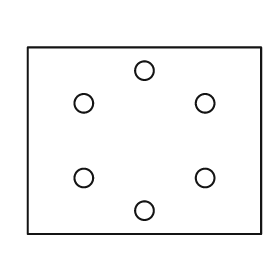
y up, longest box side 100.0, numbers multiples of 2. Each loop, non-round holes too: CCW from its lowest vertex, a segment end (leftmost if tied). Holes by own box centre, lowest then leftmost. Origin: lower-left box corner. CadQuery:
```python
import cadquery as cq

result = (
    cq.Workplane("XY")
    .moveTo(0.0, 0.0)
    .lineTo(100.0, 0.0)
    .lineTo(100.0, 80.0)
    .lineTo(0.0, 80.0)
    .close()
    .moveTo(50.0, 10.0)
    .circle(4.0)
    .moveTo(24.0, 24.0)
    .circle(4.0)
    .moveTo(76.0, 24.0)
    .circle(4.0)
    .moveTo(24.0, 56.0)
    .circle(4.0)
    .moveTo(76.0, 56.0)
    .circle(4.0)
    .moveTo(50.0, 70.0)
    .circle(4.0)
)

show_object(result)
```